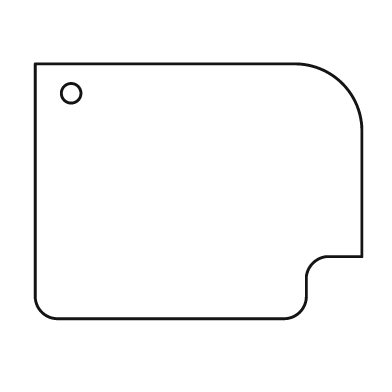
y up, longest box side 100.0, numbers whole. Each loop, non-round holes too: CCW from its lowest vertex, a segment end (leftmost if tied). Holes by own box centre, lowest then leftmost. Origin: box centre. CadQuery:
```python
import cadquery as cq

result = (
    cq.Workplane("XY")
    .moveTo(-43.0, -39.0)
    .lineTo(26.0, -39.0)
    .threePointArc((31.0, -37.0), (33.0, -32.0))
    .lineTo(33.0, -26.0)
    .threePointArc((35.0, -22.0), (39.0, -20.0))
    .lineTo(50.0, -20.0)
    .lineTo(50.0, 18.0)
    .threePointArc((44.0, 33.0), (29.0, 39.0))
    .lineTo(-50.0, 39.0)
    .lineTo(-50.0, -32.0)
    .threePointArc((-48.0, -37.0), (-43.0, -39.0))
    .close()
    .moveTo(-39.0, 30.0)
    .circle(3.0)
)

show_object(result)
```